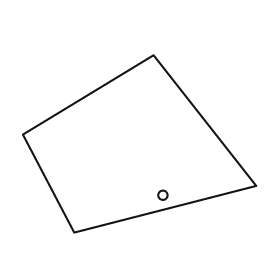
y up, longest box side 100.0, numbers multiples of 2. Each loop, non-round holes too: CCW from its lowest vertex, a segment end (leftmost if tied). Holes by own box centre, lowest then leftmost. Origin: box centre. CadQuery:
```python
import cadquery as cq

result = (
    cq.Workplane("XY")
    .moveTo(-28.0, -38.0)
    .lineTo(50.0, -18.0)
    .lineTo(6.0, 38.0)
    .lineTo(-50.0, 4.0)
    .close()
    .moveTo(10.0, -22.0)
    .circle(2.0)
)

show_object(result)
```